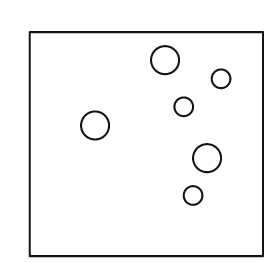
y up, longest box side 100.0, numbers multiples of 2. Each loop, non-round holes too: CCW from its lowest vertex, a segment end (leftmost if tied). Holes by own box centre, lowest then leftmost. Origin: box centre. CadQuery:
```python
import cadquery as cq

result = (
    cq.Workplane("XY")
    .moveTo(-50.0, -48.0)
    .lineTo(50.0, -48.0)
    .lineTo(50.0, 48.0)
    .lineTo(-50.0, 48.0)
    .close()
    .moveTo(20.0, -22.0)
    .circle(4.0)
    .moveTo(26.0, -6.0)
    .circle(6.0)
    .moveTo(-22.0, 8.0)
    .circle(6.0)
    .moveTo(16.0, 16.0)
    .circle(4.0)
    .moveTo(32.0, 28.0)
    .circle(4.0)
    .moveTo(8.0, 36.0)
    .circle(6.0)
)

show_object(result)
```